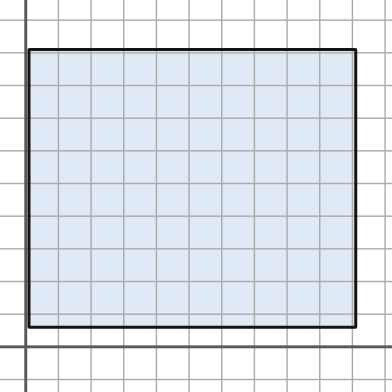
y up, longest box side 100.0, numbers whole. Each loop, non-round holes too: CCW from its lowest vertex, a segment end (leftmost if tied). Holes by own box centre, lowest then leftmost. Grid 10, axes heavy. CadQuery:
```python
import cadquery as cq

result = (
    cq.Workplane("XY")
    .moveTo(1.0, 6.0)
    .lineTo(101.0, 6.0)
    .lineTo(101.0, 91.0)
    .lineTo(1.0, 91.0)
    .close()
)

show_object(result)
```